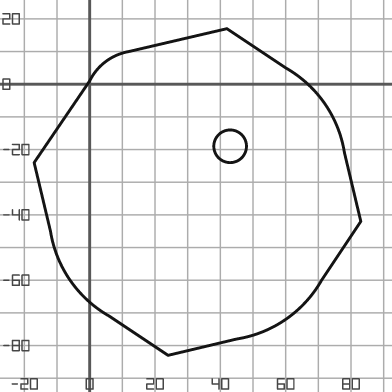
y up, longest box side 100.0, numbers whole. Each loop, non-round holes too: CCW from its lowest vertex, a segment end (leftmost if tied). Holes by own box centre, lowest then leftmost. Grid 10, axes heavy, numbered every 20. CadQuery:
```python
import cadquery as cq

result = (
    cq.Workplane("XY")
    .moveTo(24.0, -83.0)
    .lineTo(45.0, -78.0)
    .threePointArc((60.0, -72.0), (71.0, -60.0))
    .lineTo(83.0, -42.0)
    .lineTo(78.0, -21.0)
    .threePointArc((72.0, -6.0), (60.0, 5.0))
    .lineTo(42.0, 17.0)
    .lineTo(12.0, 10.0)
    .threePointArc((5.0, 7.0), (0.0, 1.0))
    .lineTo(-17.0, -24.0)
    .lineTo(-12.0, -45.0)
    .threePointArc((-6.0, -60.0), (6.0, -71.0))
    .close()
    .moveTo(43.0, -19.0)
    .circle(5.0)
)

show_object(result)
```